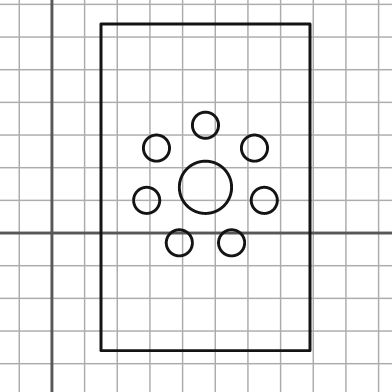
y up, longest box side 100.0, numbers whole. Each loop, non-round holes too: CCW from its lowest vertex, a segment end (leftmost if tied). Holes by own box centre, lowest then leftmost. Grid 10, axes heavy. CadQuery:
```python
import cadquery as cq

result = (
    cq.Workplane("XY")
    .moveTo(15.0, -36.0)
    .lineTo(79.0, -36.0)
    .lineTo(79.0, 64.0)
    .lineTo(15.0, 64.0)
    .close()
    .moveTo(39.0, -3.0)
    .circle(4.0)
    .moveTo(55.0, -3.0)
    .circle(4.0)
    .moveTo(29.0, 10.0)
    .circle(4.0)
    .moveTo(65.0, 10.0)
    .circle(4.0)
    .moveTo(47.0, 14.0)
    .circle(8.0)
    .moveTo(32.0, 26.0)
    .circle(4.0)
    .moveTo(62.0, 26.0)
    .circle(4.0)
    .moveTo(47.0, 33.0)
    .circle(4.0)
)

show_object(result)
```